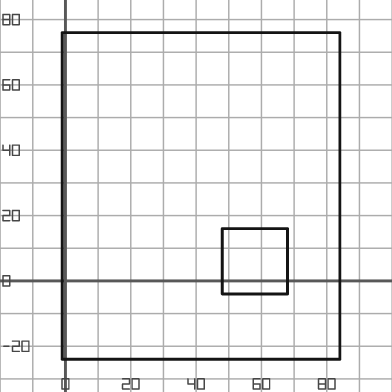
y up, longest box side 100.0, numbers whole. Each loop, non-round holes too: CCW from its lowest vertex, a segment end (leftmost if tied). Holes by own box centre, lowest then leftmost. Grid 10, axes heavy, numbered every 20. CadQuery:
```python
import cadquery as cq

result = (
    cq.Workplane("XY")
    .moveTo(-1.0, -24.0)
    .lineTo(84.0, -24.0)
    .lineTo(84.0, 76.0)
    .lineTo(-1.0, 76.0)
    .close()
    .moveTo(48.0, -4.0)
    .lineTo(68.0, -4.0)
    .lineTo(68.0, 16.0)
    .lineTo(48.0, 16.0)
    .close()
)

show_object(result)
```